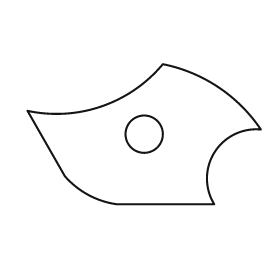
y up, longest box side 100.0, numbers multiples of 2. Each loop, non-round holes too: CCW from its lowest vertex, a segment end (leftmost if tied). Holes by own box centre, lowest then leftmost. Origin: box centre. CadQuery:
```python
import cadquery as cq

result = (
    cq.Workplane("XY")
    .moveTo(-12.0, -30.0)
    .lineTo(30.0, -30.0)
    .threePointArc((30.0, -8.0), (50.0, 2.0))
    .threePointArc((32.0, 20.0), (8.0, 30.0))
    .threePointArc((-18.0, 12.0), (-50.0, 10.0))
    .lineTo(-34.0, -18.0)
    .threePointArc((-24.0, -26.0), (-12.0, -30.0))
    .close()
    .moveTo(0.0, 0.0)
    .circle(8.0)
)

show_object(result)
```